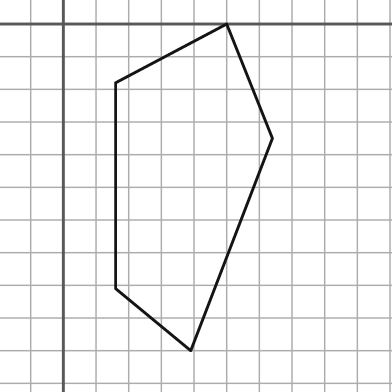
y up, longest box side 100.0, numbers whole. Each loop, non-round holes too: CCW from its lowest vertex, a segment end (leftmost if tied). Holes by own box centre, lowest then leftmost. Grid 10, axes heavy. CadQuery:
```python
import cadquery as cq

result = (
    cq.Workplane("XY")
    .moveTo(39.0, -100.0)
    .lineTo(64.0, -35.0)
    .lineTo(50.0, 0.0)
    .lineTo(16.0, -18.0)
    .lineTo(16.0, -81.0)
    .close()
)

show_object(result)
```